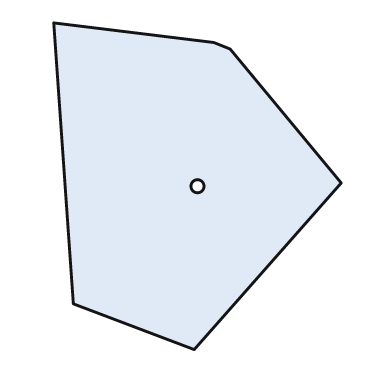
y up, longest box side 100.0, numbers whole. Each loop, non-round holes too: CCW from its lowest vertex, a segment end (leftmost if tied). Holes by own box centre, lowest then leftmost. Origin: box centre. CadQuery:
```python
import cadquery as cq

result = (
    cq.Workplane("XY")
    .moveTo(-1.0, -50.0)
    .lineTo(44.0, 1.0)
    .lineTo(10.0, 42.0)
    .lineTo(5.0, 44.0)
    .lineTo(-44.0, 50.0)
    .lineTo(-38.0, -36.0)
    .close()
    .moveTo(0.0, 0.0)
    .circle(2.0)
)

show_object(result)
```